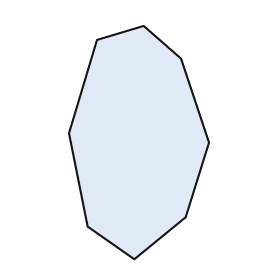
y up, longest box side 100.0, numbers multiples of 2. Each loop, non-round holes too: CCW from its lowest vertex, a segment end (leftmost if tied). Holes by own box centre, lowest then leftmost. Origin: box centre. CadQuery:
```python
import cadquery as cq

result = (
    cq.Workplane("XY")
    .moveTo(-2.0, -50.0)
    .lineTo(20.0, -32.0)
    .lineTo(30.0, 0.0)
    .lineTo(18.0, 36.0)
    .lineTo(2.0, 50.0)
    .lineTo(-18.0, 44.0)
    .lineTo(-30.0, 4.0)
    .lineTo(-22.0, -36.0)
    .close()
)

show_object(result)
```